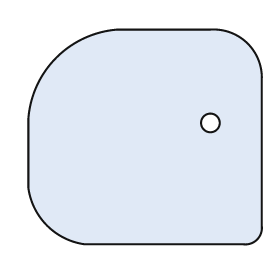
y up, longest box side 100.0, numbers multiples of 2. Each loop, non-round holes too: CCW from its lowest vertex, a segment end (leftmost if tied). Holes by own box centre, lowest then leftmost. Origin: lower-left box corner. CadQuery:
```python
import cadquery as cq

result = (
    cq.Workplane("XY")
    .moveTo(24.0, 0.0)
    .lineTo(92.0, 0.0)
    .threePointArc((98.0, 2.0), (100.0, 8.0))
    .lineTo(100.0, 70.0)
    .threePointArc((94.0, 86.0), (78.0, 92.0))
    .lineTo(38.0, 92.0)
    .threePointArc((12.0, 80.0), (0.0, 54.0))
    .lineTo(0.0, 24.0)
    .threePointArc((8.0, 8.0), (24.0, 0.0))
    .close()
    .moveTo(78.0, 52.0)
    .circle(4.0)
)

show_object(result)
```